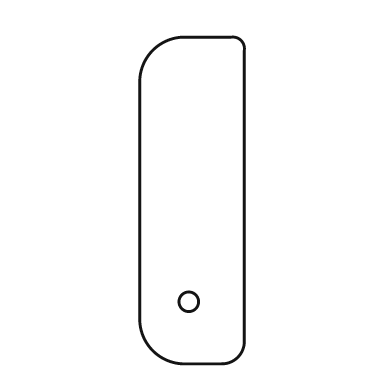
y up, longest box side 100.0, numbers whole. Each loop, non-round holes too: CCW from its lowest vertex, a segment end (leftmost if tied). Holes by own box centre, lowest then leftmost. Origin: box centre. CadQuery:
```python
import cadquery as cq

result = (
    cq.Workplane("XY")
    .moveTo(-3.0, -50.0)
    .lineTo(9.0, -50.0)
    .threePointArc((14.0, -48.0), (16.0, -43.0))
    .lineTo(16.0, 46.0)
    .threePointArc((15.0, 49.0), (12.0, 50.0))
    .lineTo(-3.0, 50.0)
    .threePointArc((-12.0, 46.0), (-16.0, 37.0))
    .lineTo(-16.0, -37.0)
    .threePointArc((-12.0, -46.0), (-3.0, -50.0))
    .close()
    .moveTo(-1.0, -31.0)
    .circle(3.0)
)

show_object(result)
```